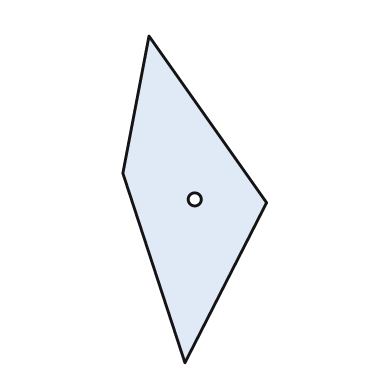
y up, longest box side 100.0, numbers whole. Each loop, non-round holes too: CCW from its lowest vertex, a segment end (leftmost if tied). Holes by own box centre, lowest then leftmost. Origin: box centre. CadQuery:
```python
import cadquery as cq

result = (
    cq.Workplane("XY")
    .moveTo(-3.0, -50.0)
    .lineTo(22.0, -1.0)
    .lineTo(-14.0, 50.0)
    .lineTo(-22.0, 8.0)
    .close()
    .moveTo(0.0, 0.0)
    .circle(2.0)
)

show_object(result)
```